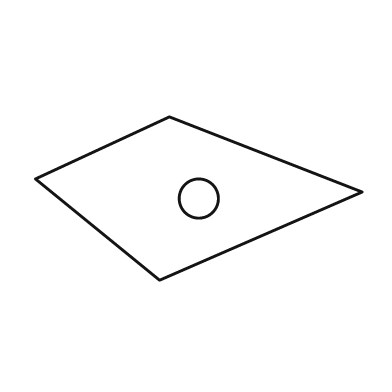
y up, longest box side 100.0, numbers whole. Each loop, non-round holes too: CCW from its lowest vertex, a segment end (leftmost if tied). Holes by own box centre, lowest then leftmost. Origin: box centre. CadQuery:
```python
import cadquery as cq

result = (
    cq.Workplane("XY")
    .moveTo(-12.0, -25.0)
    .lineTo(50.0, 2.0)
    .lineTo(-9.0, 25.0)
    .lineTo(-50.0, 6.0)
    .close()
    .moveTo(0.0, 0.0)
    .circle(6.0)
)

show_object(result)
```